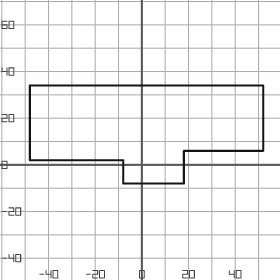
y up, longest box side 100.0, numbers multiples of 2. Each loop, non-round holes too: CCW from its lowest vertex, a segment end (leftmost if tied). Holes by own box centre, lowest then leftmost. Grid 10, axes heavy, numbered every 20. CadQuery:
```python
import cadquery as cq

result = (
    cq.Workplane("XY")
    .moveTo(-8.0, -8.0)
    .lineTo(18.0, -8.0)
    .lineTo(18.0, 6.0)
    .lineTo(52.0, 6.0)
    .lineTo(52.0, 34.0)
    .lineTo(-48.0, 34.0)
    .lineTo(-48.0, 2.0)
    .lineTo(-8.0, 2.0)
    .close()
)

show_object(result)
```